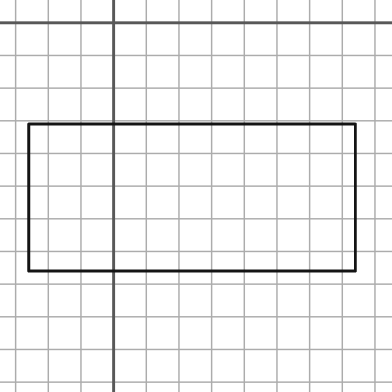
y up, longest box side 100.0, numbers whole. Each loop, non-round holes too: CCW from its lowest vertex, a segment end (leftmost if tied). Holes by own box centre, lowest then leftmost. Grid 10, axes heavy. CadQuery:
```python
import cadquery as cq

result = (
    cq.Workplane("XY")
    .moveTo(-26.0, -76.0)
    .lineTo(74.0, -76.0)
    .lineTo(74.0, -31.0)
    .lineTo(-26.0, -31.0)
    .close()
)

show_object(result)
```